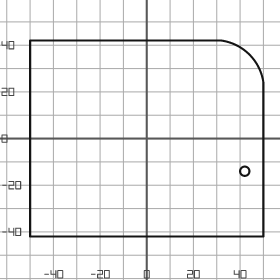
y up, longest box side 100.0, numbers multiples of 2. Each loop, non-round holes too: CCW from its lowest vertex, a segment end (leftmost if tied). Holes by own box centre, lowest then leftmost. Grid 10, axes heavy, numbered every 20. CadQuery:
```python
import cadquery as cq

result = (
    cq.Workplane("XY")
    .moveTo(-50.0, -42.0)
    .lineTo(50.0, -42.0)
    .lineTo(50.0, 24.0)
    .threePointArc((44.0, 36.0), (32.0, 42.0))
    .lineTo(-50.0, 42.0)
    .close()
    .moveTo(42.0, -14.0)
    .circle(2.0)
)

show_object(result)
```